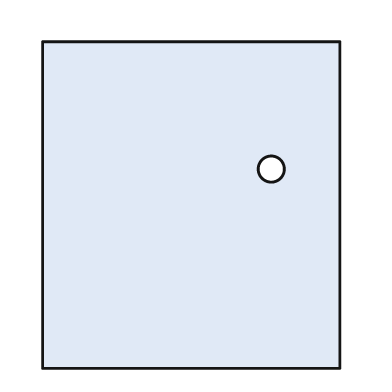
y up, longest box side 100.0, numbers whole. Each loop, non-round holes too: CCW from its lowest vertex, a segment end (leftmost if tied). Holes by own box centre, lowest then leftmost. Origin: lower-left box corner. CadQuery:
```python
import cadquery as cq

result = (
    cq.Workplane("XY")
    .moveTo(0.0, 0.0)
    .lineTo(91.0, 0.0)
    .lineTo(91.0, 100.0)
    .lineTo(0.0, 100.0)
    .close()
    .moveTo(70.0, 61.0)
    .circle(4.0)
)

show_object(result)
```